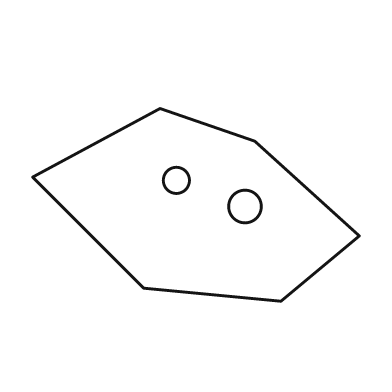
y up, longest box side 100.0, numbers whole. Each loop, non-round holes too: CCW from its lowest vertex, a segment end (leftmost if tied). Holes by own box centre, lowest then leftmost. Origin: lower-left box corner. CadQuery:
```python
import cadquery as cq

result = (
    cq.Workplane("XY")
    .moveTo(76.0, 0.0)
    .lineTo(100.0, 20.0)
    .lineTo(68.0, 49.0)
    .lineTo(39.0, 59.0)
    .lineTo(0.0, 38.0)
    .lineTo(34.0, 4.0)
    .close()
    .moveTo(65.0, 29.0)
    .circle(5.0)
    .moveTo(44.0, 37.0)
    .circle(4.0)
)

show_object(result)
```